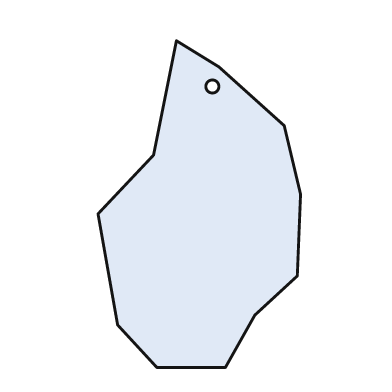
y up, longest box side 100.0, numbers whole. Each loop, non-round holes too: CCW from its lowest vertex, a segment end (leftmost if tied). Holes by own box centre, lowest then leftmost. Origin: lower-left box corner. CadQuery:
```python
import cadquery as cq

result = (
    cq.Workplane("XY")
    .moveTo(18.0, 0.0)
    .lineTo(39.0, 0.0)
    .lineTo(48.0, 16.0)
    .lineTo(61.0, 28.0)
    .lineTo(62.0, 53.0)
    .lineTo(57.0, 74.0)
    .lineTo(37.0, 92.0)
    .lineTo(24.0, 100.0)
    .lineTo(17.0, 65.0)
    .lineTo(0.0, 47.0)
    .lineTo(6.0, 13.0)
    .close()
    .moveTo(35.0, 86.0)
    .circle(2.0)
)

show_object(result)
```